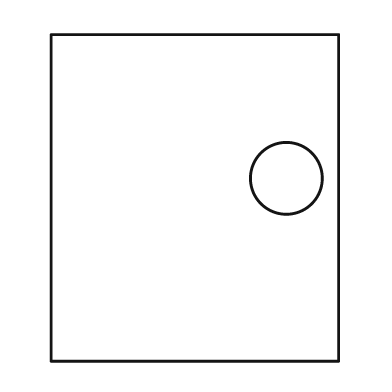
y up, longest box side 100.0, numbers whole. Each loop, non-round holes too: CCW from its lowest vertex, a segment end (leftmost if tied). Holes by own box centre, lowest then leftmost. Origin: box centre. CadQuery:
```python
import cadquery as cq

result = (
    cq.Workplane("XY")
    .moveTo(-44.0, -50.0)
    .lineTo(44.0, -50.0)
    .lineTo(44.0, 50.0)
    .lineTo(-44.0, 50.0)
    .close()
    .moveTo(28.0, 6.0)
    .circle(11.0)
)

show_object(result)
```